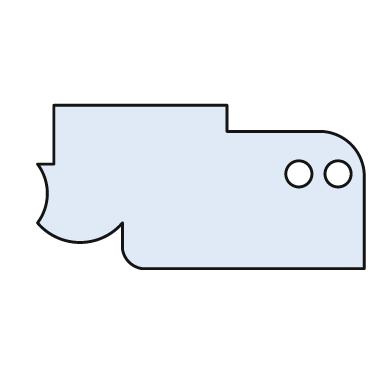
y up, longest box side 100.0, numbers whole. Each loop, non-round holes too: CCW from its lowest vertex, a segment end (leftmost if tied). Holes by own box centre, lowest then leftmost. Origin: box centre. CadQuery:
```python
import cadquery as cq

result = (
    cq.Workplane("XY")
    .moveTo(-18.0, -25.0)
    .lineTo(50.0, -25.0)
    .lineTo(50.0, 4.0)
    .threePointArc((46.0, 13.0), (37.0, 17.0))
    .lineTo(8.0, 17.0)
    .lineTo(8.0, 25.0)
    .lineTo(-45.0, 25.0)
    .lineTo(-45.0, 7.0)
    .lineTo(-50.0, 7.0)
    .threePointArc((-47.0, -2.0), (-50.0, -11.0))
    .threePointArc((-37.0, -17.0), (-24.0, -11.0))
    .lineTo(-24.0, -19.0)
    .threePointArc((-22.0, -23.0), (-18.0, -25.0))
    .close()
    .moveTo(30.0, 4.0)
    .circle(4.0)
    .moveTo(42.0, 4.0)
    .circle(4.0)
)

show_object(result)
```